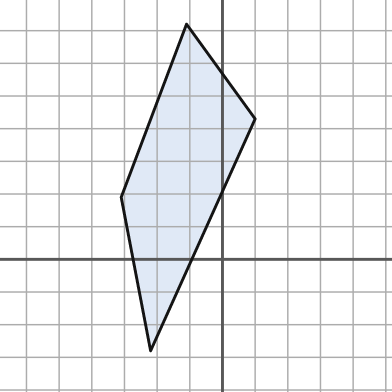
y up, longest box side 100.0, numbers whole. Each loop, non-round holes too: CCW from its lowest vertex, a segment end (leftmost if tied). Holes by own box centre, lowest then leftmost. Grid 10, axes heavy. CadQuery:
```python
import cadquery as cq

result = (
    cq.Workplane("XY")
    .moveTo(-22.0, -28.0)
    .lineTo(10.0, 43.0)
    .lineTo(-11.0, 72.0)
    .lineTo(-31.0, 19.0)
    .close()
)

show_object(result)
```